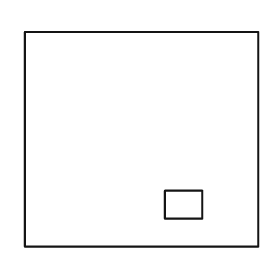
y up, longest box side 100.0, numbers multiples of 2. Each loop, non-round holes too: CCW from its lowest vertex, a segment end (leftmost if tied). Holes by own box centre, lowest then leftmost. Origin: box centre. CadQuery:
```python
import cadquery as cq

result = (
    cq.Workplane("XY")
    .moveTo(-50.0, -46.0)
    .lineTo(50.0, -46.0)
    .lineTo(50.0, 46.0)
    .lineTo(-50.0, 46.0)
    .close()
    .moveTo(10.0, -34.0)
    .lineTo(26.0, -34.0)
    .lineTo(26.0, -22.0)
    .lineTo(10.0, -22.0)
    .close()
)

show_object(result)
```